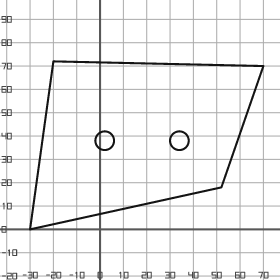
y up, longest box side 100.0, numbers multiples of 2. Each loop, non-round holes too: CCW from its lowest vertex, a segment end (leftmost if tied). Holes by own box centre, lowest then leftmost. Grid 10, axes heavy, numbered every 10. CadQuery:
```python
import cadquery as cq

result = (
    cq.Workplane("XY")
    .moveTo(-30.0, 0.0)
    .lineTo(52.0, 18.0)
    .lineTo(70.0, 70.0)
    .lineTo(-20.0, 72.0)
    .close()
    .moveTo(2.0, 38.0)
    .circle(4.0)
    .moveTo(34.0, 38.0)
    .circle(4.0)
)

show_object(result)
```